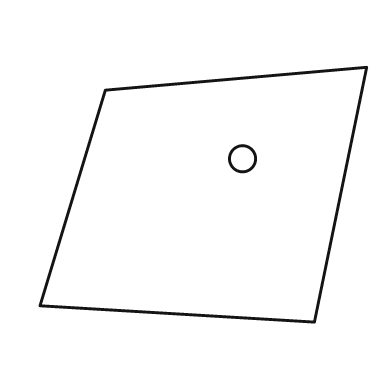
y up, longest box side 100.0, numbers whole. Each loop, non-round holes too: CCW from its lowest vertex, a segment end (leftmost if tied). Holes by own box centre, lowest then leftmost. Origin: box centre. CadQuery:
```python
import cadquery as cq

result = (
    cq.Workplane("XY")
    .moveTo(34.0, -39.0)
    .lineTo(50.0, 39.0)
    .lineTo(-30.0, 32.0)
    .lineTo(-50.0, -34.0)
    .close()
    .moveTo(12.0, 11.0)
    .circle(4.0)
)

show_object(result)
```